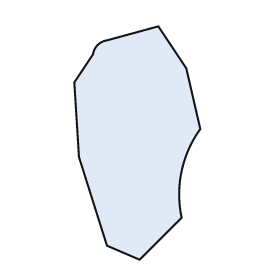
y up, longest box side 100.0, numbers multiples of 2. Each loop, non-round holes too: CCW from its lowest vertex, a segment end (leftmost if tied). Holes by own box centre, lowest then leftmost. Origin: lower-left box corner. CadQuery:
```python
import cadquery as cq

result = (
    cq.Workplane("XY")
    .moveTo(28.0, 0.0)
    .lineTo(46.0, 18.0)
    .threePointArc((46.0, 38.0), (54.0, 56.0))
    .lineTo(48.0, 82.0)
    .lineTo(36.0, 100.0)
    .lineTo(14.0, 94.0)
    .threePointArc((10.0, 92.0), (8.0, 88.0))
    .lineTo(0.0, 76.0)
    .lineTo(2.0, 44.0)
    .lineTo(14.0, 6.0)
    .close()
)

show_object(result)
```